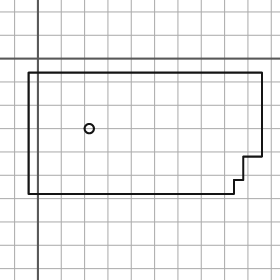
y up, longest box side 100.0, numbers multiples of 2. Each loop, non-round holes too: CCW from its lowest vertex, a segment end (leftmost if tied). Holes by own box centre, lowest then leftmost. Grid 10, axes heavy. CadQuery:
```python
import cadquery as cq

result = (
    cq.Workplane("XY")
    .moveTo(-4.0, -58.0)
    .lineTo(84.0, -58.0)
    .lineTo(84.0, -52.0)
    .lineTo(88.0, -52.0)
    .lineTo(88.0, -42.0)
    .lineTo(96.0, -42.0)
    .lineTo(96.0, -6.0)
    .lineTo(-4.0, -6.0)
    .close()
    .moveTo(22.0, -30.0)
    .circle(2.0)
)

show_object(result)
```